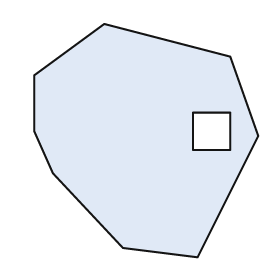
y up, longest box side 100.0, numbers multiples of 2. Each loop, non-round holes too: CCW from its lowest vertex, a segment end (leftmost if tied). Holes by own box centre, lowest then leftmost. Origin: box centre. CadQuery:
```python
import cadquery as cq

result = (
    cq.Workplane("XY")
    .moveTo(22.0, -50.0)
    .lineTo(48.0, 2.0)
    .lineTo(36.0, 36.0)
    .lineTo(-18.0, 50.0)
    .lineTo(-48.0, 28.0)
    .lineTo(-48.0, 4.0)
    .lineTo(-40.0, -14.0)
    .lineTo(-10.0, -46.0)
    .close()
    .moveTo(20.0, -4.0)
    .lineTo(36.0, -4.0)
    .lineTo(36.0, 12.0)
    .lineTo(20.0, 12.0)
    .close()
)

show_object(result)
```